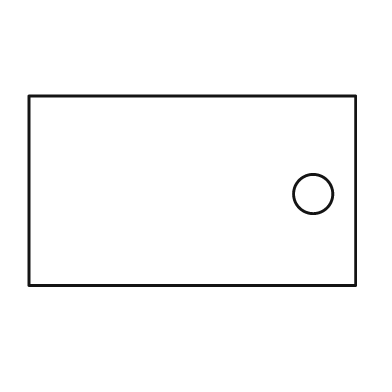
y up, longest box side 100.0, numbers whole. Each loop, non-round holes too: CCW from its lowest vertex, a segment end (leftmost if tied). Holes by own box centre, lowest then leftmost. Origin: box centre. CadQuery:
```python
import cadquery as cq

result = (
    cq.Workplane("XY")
    .moveTo(-50.0, -29.0)
    .lineTo(50.0, -29.0)
    .lineTo(50.0, 29.0)
    .lineTo(-50.0, 29.0)
    .close()
    .moveTo(37.0, -1.0)
    .circle(6.0)
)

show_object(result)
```